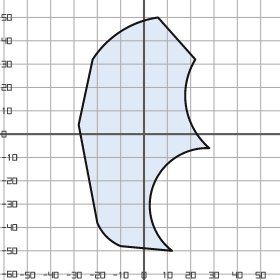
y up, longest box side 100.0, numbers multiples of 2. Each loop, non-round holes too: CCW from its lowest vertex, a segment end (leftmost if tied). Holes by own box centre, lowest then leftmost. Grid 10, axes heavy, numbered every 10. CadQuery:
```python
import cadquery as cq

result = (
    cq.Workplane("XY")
    .moveTo(12.0, -50.0)
    .threePointArc((4.0, -22.0), (28.0, -6.0))
    .threePointArc((18.0, 12.0), (22.0, 32.0))
    .lineTo(6.0, 50.0)
    .threePointArc((-10.0, 44.0), (-22.0, 32.0))
    .lineTo(-28.0, 4.0)
    .lineTo(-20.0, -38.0)
    .threePointArc((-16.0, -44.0), (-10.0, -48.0))
    .close()
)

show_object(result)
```